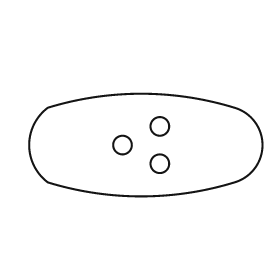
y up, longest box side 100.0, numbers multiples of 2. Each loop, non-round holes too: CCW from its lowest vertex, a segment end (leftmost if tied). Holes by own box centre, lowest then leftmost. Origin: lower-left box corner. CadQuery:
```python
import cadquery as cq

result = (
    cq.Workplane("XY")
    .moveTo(8.0, 6.0)
    .threePointArc((48.0, 0.0), (88.0, 6.0))
    .threePointArc((100.0, 22.0), (88.0, 38.0))
    .threePointArc((48.0, 44.0), (8.0, 38.0))
    .threePointArc((0.0, 22.0), (8.0, 6.0))
    .close()
    .moveTo(56.0, 14.0)
    .circle(4.0)
    .moveTo(40.0, 22.0)
    .circle(4.0)
    .moveTo(56.0, 30.0)
    .circle(4.0)
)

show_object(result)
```